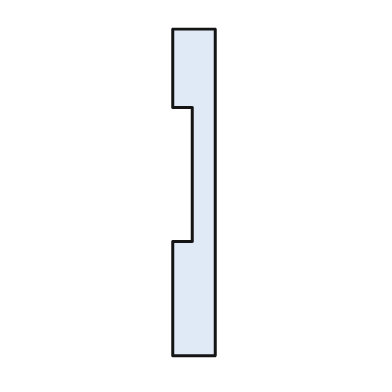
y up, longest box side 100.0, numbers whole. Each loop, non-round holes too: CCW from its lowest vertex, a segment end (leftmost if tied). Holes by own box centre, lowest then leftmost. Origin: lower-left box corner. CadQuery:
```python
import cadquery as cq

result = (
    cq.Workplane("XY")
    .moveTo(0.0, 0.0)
    .lineTo(13.0, 0.0)
    .lineTo(13.0, 100.0)
    .lineTo(0.0, 100.0)
    .lineTo(0.0, 76.0)
    .lineTo(6.0, 76.0)
    .lineTo(6.0, 35.0)
    .lineTo(0.0, 35.0)
    .close()
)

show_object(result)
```